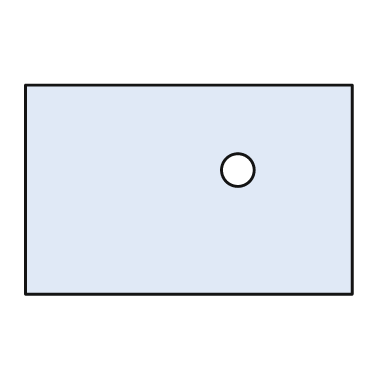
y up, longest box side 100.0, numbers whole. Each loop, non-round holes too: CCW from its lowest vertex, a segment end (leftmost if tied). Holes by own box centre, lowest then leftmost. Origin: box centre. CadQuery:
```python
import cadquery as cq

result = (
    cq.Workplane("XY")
    .moveTo(-50.0, -32.0)
    .lineTo(50.0, -32.0)
    .lineTo(50.0, 32.0)
    .lineTo(-50.0, 32.0)
    .close()
    .moveTo(15.0, 6.0)
    .circle(5.0)
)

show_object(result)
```